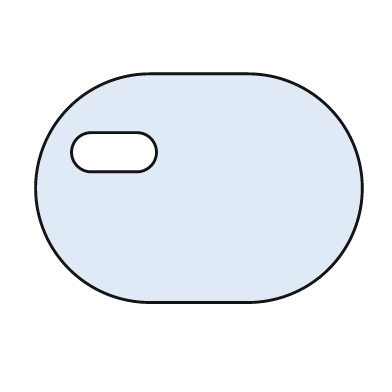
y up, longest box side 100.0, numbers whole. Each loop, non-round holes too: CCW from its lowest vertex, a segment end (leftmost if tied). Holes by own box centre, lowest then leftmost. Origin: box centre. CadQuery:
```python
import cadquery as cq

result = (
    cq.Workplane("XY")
    .moveTo(-15.0, -35.0)
    .lineTo(15.0, -35.0)
    .threePointArc((50.0, 0.0), (15.0, 35.0))
    .lineTo(-15.0, 35.0)
    .threePointArc((-50.0, 0.0), (-15.0, -35.0))
    .close()
    .moveTo(-33.0, 5.0)
    .lineTo(-19.0, 5.0)
    .threePointArc((-13.0, 11.0), (-19.0, 17.0))
    .lineTo(-33.0, 17.0)
    .threePointArc((-39.0, 11.0), (-33.0, 5.0))
    .close()
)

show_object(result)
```